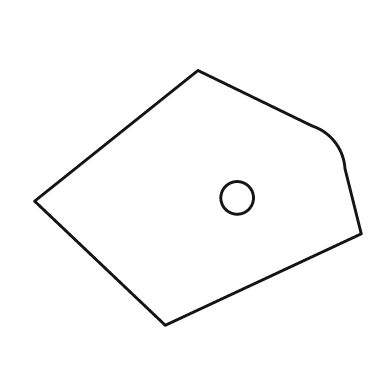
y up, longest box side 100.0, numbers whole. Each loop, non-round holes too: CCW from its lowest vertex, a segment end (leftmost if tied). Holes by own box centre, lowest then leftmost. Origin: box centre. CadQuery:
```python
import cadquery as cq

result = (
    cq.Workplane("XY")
    .moveTo(-10.0, -39.0)
    .lineTo(50.0, -11.0)
    .lineTo(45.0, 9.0)
    .threePointArc((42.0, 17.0), (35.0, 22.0))
    .lineTo(0.0, 39.0)
    .lineTo(-50.0, -1.0)
    .close()
    .moveTo(12.0, 0.0)
    .circle(5.0)
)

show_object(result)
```